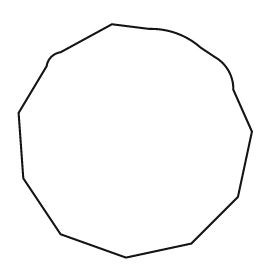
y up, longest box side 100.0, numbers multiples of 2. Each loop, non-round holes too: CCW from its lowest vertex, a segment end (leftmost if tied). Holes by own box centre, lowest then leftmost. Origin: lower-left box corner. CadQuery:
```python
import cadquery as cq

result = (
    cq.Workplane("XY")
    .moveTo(46.0, 0.0)
    .lineTo(74.0, 6.0)
    .lineTo(94.0, 26.0)
    .lineTo(100.0, 54.0)
    .lineTo(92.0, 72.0)
    .threePointArc((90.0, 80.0), (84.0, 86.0))
    .lineTo(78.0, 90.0)
    .threePointArc((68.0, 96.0), (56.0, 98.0))
    .lineTo(40.0, 100.0)
    .lineTo(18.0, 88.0)
    .threePointArc((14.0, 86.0), (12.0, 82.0))
    .lineTo(0.0, 62.0)
    .lineTo(2.0, 34.0)
    .lineTo(18.0, 10.0)
    .close()
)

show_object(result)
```